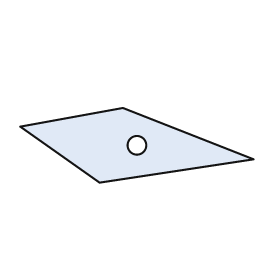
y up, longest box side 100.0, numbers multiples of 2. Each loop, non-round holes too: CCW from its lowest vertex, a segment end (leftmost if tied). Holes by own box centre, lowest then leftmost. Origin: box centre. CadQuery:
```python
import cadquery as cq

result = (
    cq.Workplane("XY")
    .moveTo(-16.0, -16.0)
    .lineTo(50.0, -6.0)
    .lineTo(-6.0, 16.0)
    .lineTo(-50.0, 8.0)
    .close()
    .moveTo(0.0, 0.0)
    .circle(4.0)
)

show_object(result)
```